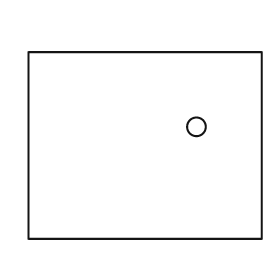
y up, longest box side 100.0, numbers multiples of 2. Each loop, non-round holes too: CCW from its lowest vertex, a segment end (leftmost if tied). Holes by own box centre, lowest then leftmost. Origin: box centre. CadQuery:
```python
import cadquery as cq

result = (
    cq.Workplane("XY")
    .moveTo(-50.0, -40.0)
    .lineTo(50.0, -40.0)
    .lineTo(50.0, 40.0)
    .lineTo(-50.0, 40.0)
    .close()
    .moveTo(22.0, 8.0)
    .circle(4.0)
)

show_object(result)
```